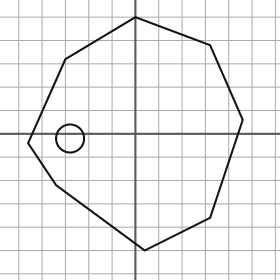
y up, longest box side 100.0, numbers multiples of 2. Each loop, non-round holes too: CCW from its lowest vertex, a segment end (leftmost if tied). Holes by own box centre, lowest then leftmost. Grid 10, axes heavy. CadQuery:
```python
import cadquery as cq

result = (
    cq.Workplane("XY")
    .moveTo(4.0, -50.0)
    .lineTo(32.0, -36.0)
    .lineTo(46.0, 6.0)
    .lineTo(32.0, 38.0)
    .lineTo(0.0, 50.0)
    .lineTo(-30.0, 32.0)
    .lineTo(-46.0, -4.0)
    .lineTo(-34.0, -22.0)
    .close()
    .moveTo(-28.0, -2.0)
    .circle(6.0)
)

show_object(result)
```